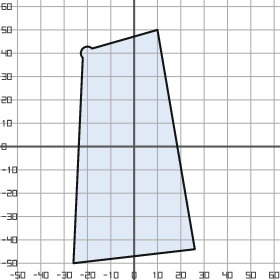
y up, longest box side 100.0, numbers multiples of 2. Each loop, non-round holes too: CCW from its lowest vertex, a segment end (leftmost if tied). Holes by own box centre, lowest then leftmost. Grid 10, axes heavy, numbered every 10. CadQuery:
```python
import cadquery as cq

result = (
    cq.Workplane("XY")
    .moveTo(-26.0, -50.0)
    .lineTo(26.0, -44.0)
    .lineTo(10.0, 50.0)
    .lineTo(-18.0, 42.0)
    .threePointArc((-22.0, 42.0), (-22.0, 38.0))
    .close()
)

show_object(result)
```